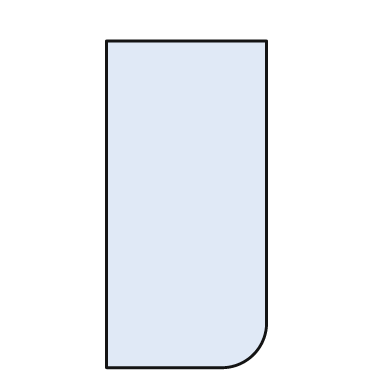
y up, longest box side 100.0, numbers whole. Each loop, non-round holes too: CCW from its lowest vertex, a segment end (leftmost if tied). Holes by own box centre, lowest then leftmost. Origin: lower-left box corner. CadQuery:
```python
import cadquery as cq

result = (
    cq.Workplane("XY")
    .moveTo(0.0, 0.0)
    .lineTo(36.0, 0.0)
    .threePointArc((45.0, 4.0), (49.0, 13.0))
    .lineTo(49.0, 100.0)
    .lineTo(0.0, 100.0)
    .close()
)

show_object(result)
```